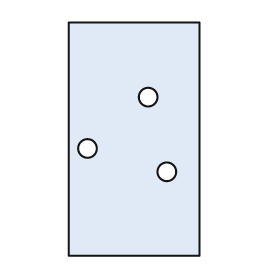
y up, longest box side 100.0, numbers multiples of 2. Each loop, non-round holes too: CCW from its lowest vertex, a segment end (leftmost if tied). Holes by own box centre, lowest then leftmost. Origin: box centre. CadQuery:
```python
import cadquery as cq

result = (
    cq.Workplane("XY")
    .moveTo(-28.0, -50.0)
    .lineTo(28.0, -50.0)
    .lineTo(28.0, 50.0)
    .lineTo(-28.0, 50.0)
    .close()
    .moveTo(14.0, -14.0)
    .circle(4.0)
    .moveTo(-20.0, -4.0)
    .circle(4.0)
    .moveTo(6.0, 18.0)
    .circle(4.0)
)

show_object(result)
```